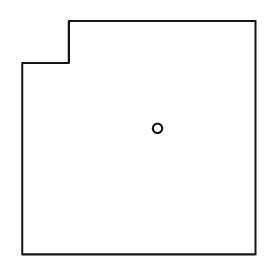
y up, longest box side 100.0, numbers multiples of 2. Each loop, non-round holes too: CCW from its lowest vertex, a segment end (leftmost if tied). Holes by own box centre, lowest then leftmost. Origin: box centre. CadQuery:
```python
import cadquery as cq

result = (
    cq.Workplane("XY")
    .moveTo(-50.0, -50.0)
    .lineTo(50.0, -50.0)
    .lineTo(50.0, 50.0)
    .lineTo(-30.0, 50.0)
    .lineTo(-30.0, 32.0)
    .lineTo(-50.0, 32.0)
    .close()
    .moveTo(8.0, 4.0)
    .circle(2.0)
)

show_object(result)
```